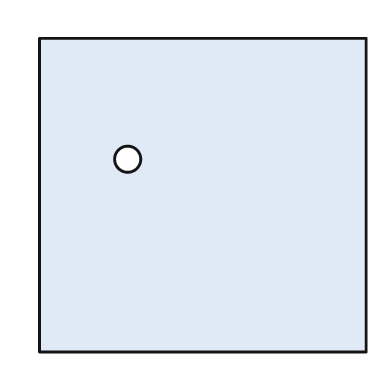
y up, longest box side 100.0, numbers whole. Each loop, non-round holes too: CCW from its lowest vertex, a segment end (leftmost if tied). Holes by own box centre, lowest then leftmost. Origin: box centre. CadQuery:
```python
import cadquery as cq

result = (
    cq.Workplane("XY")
    .moveTo(-50.0, -48.0)
    .lineTo(50.0, -48.0)
    .lineTo(50.0, 48.0)
    .lineTo(-50.0, 48.0)
    .close()
    .moveTo(-23.0, 11.0)
    .circle(4.0)
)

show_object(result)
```